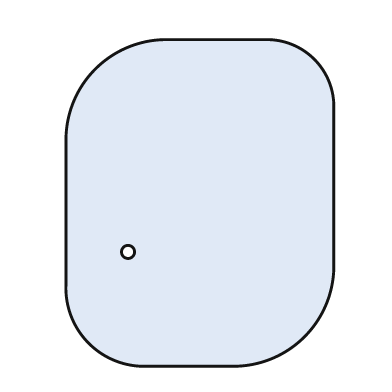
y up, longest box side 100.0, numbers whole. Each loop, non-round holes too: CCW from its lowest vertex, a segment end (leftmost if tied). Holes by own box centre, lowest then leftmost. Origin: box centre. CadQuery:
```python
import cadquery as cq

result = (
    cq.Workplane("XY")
    .moveTo(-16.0, -50.0)
    .lineTo(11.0, -50.0)
    .threePointArc((32.0, -41.0), (41.0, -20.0))
    .lineTo(41.0, 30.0)
    .threePointArc((35.0, 44.0), (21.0, 50.0))
    .lineTo(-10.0, 50.0)
    .threePointArc((-32.0, 41.0), (-41.0, 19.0))
    .lineTo(-41.0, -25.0)
    .threePointArc((-34.0, -43.0), (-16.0, -50.0))
    .close()
    .moveTo(-22.0, -15.0)
    .circle(2.0)
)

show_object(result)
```